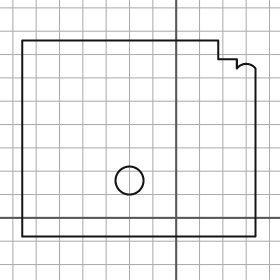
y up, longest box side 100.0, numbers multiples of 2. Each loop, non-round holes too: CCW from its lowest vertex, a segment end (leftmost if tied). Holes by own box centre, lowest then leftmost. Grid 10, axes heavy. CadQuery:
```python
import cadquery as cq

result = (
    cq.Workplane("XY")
    .moveTo(-66.0, -8.0)
    .lineTo(34.0, -8.0)
    .lineTo(34.0, 64.0)
    .threePointArc((30.0, 66.0), (26.0, 64.0))
    .lineTo(26.0, 68.0)
    .lineTo(18.0, 68.0)
    .lineTo(18.0, 76.0)
    .lineTo(-66.0, 76.0)
    .close()
    .moveTo(-20.0, 16.0)
    .circle(6.0)
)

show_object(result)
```